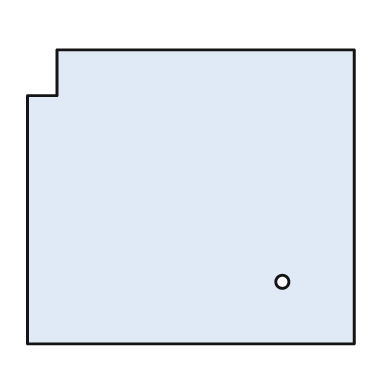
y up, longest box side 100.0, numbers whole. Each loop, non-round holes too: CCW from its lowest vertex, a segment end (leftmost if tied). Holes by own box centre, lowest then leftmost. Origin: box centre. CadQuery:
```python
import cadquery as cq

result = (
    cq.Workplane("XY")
    .moveTo(-50.0, -45.0)
    .lineTo(50.0, -45.0)
    .lineTo(50.0, 45.0)
    .lineTo(-41.0, 45.0)
    .lineTo(-41.0, 31.0)
    .lineTo(-50.0, 31.0)
    .close()
    .moveTo(28.0, -26.0)
    .circle(2.0)
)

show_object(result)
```